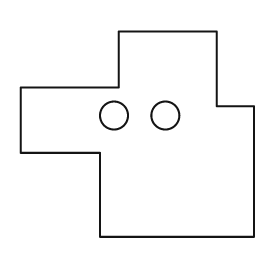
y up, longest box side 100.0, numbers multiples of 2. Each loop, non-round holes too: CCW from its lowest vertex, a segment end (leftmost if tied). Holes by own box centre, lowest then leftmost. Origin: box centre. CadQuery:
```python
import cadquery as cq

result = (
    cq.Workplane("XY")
    .moveTo(-16.0, -44.0)
    .lineTo(50.0, -44.0)
    .lineTo(50.0, 12.0)
    .lineTo(34.0, 12.0)
    .lineTo(34.0, 44.0)
    .lineTo(-8.0, 44.0)
    .lineTo(-8.0, 20.0)
    .lineTo(-50.0, 20.0)
    .lineTo(-50.0, -8.0)
    .lineTo(-16.0, -8.0)
    .close()
    .moveTo(-10.0, 8.0)
    .circle(6.0)
    .moveTo(12.0, 8.0)
    .circle(6.0)
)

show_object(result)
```